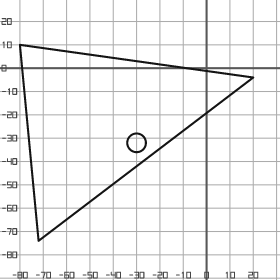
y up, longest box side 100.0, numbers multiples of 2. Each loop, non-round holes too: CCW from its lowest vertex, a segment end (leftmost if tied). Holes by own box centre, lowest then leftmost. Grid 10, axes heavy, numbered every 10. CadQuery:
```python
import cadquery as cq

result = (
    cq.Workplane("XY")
    .moveTo(-72.0, -74.0)
    .lineTo(20.0, -4.0)
    .lineTo(-80.0, 10.0)
    .close()
    .moveTo(-30.0, -32.0)
    .circle(4.0)
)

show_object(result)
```